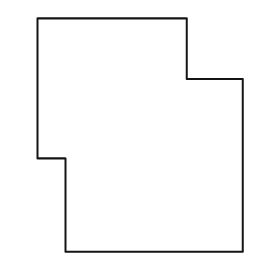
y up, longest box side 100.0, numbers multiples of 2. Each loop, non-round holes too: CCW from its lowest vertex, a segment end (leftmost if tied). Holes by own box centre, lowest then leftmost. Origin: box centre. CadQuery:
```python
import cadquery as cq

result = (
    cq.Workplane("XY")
    .moveTo(-32.0, -50.0)
    .lineTo(44.0, -50.0)
    .lineTo(44.0, 24.0)
    .lineTo(20.0, 24.0)
    .lineTo(20.0, 50.0)
    .lineTo(-44.0, 50.0)
    .lineTo(-44.0, -10.0)
    .lineTo(-32.0, -10.0)
    .close()
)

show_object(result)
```